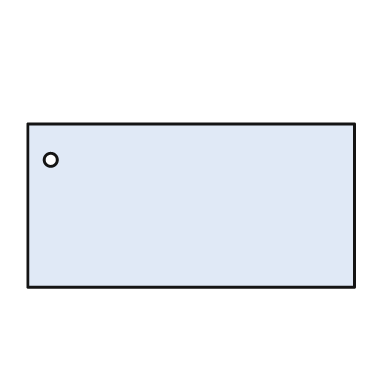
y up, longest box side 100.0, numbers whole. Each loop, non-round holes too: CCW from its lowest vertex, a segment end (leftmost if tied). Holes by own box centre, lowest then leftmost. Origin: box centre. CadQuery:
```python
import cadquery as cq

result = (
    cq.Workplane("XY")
    .moveTo(-50.0, -25.0)
    .lineTo(50.0, -25.0)
    .lineTo(50.0, 25.0)
    .lineTo(-50.0, 25.0)
    .close()
    .moveTo(-43.0, 14.0)
    .circle(2.0)
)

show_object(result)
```